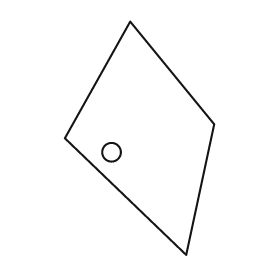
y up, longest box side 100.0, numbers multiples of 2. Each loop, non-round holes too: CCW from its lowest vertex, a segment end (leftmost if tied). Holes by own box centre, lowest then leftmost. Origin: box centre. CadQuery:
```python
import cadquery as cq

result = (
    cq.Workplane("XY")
    .moveTo(20.0, -50.0)
    .lineTo(32.0, 6.0)
    .lineTo(-4.0, 50.0)
    .lineTo(-32.0, 0.0)
    .close()
    .moveTo(-12.0, -6.0)
    .circle(4.0)
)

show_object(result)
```